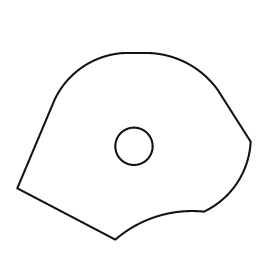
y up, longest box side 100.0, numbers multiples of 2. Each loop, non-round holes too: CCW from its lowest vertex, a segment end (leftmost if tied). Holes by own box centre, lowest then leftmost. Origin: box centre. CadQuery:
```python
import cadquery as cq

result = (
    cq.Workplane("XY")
    .moveTo(-8.0, -40.0)
    .threePointArc((10.0, -30.0), (30.0, -28.0))
    .threePointArc((44.0, -16.0), (50.0, 2.0))
    .lineTo(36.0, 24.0)
    .threePointArc((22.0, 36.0), (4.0, 40.0))
    .lineTo(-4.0, 40.0)
    .threePointArc((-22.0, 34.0), (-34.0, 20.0))
    .lineTo(-50.0, -18.0)
    .close()
    .moveTo(0.0, 0.0)
    .circle(8.0)
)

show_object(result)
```